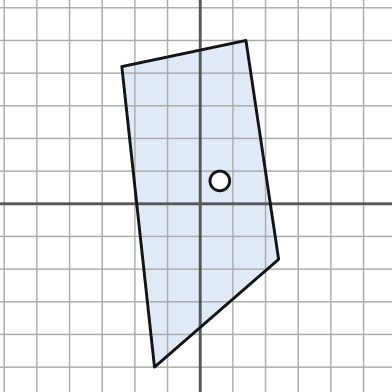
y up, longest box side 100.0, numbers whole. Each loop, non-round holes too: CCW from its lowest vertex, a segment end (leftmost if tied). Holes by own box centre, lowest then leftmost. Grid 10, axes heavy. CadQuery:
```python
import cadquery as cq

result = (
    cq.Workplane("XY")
    .moveTo(-14.0, -50.0)
    .lineTo(24.0, -17.0)
    .lineTo(14.0, 50.0)
    .lineTo(-24.0, 42.0)
    .close()
    .moveTo(6.0, 7.0)
    .circle(3.0)
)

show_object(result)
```